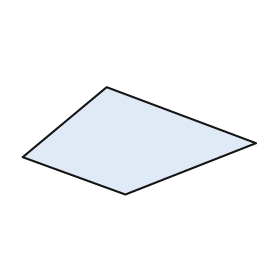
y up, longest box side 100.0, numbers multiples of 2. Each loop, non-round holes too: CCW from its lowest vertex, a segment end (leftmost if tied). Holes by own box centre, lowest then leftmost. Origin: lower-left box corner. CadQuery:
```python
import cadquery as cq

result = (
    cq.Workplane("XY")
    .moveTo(44.0, 0.0)
    .lineTo(100.0, 22.0)
    .lineTo(36.0, 46.0)
    .lineTo(0.0, 16.0)
    .close()
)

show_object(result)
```